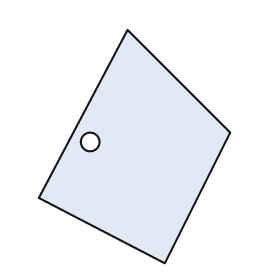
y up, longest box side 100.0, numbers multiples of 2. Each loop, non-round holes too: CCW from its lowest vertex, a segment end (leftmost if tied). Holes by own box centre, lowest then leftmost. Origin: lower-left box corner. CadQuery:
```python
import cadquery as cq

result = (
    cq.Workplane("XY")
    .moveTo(54.0, 0.0)
    .lineTo(82.0, 56.0)
    .lineTo(38.0, 100.0)
    .lineTo(0.0, 28.0)
    .close()
    .moveTo(22.0, 52.0)
    .circle(4.0)
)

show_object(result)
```